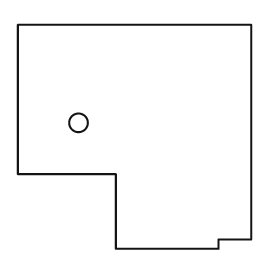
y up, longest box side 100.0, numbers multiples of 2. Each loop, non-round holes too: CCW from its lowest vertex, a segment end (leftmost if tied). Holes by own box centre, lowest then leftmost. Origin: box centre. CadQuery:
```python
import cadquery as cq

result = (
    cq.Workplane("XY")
    .moveTo(-8.0, -48.0)
    .lineTo(36.0, -48.0)
    .lineTo(36.0, -44.0)
    .lineTo(50.0, -44.0)
    .lineTo(50.0, 48.0)
    .lineTo(-50.0, 48.0)
    .lineTo(-50.0, -16.0)
    .lineTo(-8.0, -16.0)
    .close()
    .moveTo(-24.0, 6.0)
    .circle(4.0)
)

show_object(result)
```